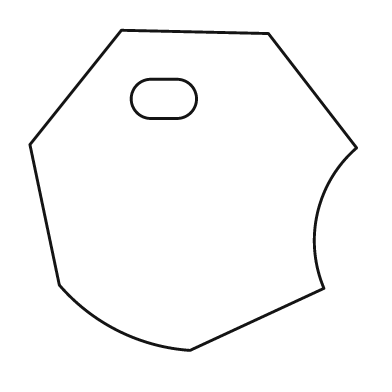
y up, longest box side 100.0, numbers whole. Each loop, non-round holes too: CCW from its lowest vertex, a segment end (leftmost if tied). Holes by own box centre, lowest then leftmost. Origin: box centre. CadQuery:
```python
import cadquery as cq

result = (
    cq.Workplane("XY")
    .moveTo(-1.0, -49.0)
    .lineTo(40.0, -30.0)
    .threePointArc((38.0, -7.0), (50.0, 13.0))
    .lineTo(23.0, 48.0)
    .lineTo(-22.0, 49.0)
    .lineTo(-50.0, 14.0)
    .lineTo(-41.0, -29.0)
    .threePointArc((-23.0, -43.0), (-1.0, -49.0))
    .close()
    .moveTo(-13.0, 22.0)
    .lineTo(-5.0, 22.0)
    .threePointArc((1.0, 28.0), (-5.0, 34.0))
    .lineTo(-13.0, 34.0)
    .threePointArc((-19.0, 28.0), (-13.0, 22.0))
    .close()
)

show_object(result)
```